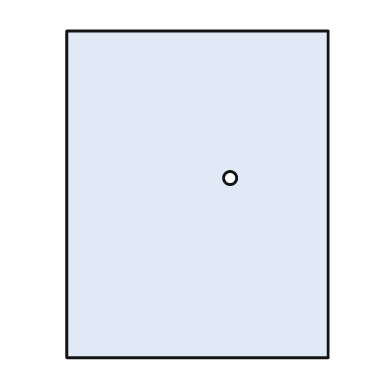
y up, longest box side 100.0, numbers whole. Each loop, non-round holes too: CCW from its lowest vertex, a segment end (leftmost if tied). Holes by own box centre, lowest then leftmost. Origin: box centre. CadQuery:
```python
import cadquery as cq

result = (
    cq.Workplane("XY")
    .moveTo(-40.0, -50.0)
    .lineTo(40.0, -50.0)
    .lineTo(40.0, 50.0)
    .lineTo(-40.0, 50.0)
    .close()
    .moveTo(10.0, 5.0)
    .circle(2.0)
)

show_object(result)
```